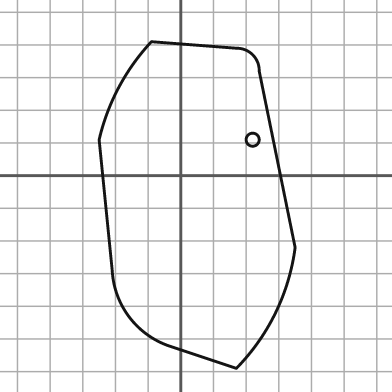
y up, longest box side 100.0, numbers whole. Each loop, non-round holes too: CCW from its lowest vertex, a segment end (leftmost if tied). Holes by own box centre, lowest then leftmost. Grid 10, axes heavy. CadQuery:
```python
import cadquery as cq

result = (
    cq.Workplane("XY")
    .moveTo(17.0, -59.0)
    .threePointArc((29.0, -42.0), (35.0, -22.0))
    .lineTo(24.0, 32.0)
    .threePointArc((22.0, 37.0), (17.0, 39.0))
    .lineTo(-9.0, 41.0)
    .threePointArc((-19.0, 27.0), (-25.0, 11.0))
    .lineTo(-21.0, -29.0)
    .threePointArc((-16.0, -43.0), (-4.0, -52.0))
    .close()
    .moveTo(22.0, 11.0)
    .circle(2.0)
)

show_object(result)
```